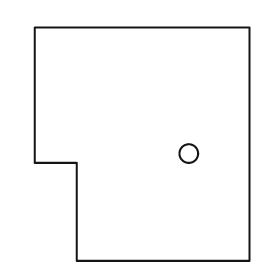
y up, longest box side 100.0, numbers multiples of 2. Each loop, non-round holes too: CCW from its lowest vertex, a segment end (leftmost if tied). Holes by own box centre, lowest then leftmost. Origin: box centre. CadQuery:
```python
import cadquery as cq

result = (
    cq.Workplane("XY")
    .moveTo(-28.0, -50.0)
    .lineTo(46.0, -50.0)
    .lineTo(46.0, 50.0)
    .lineTo(-46.0, 50.0)
    .lineTo(-46.0, -8.0)
    .lineTo(-28.0, -8.0)
    .close()
    .moveTo(20.0, -4.0)
    .circle(4.0)
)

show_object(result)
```